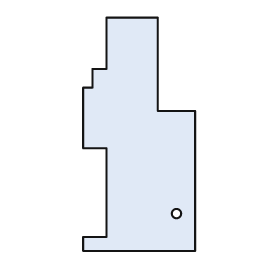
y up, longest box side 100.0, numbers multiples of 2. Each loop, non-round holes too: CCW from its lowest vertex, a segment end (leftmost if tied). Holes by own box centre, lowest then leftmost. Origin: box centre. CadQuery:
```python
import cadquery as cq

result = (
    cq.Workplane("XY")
    .moveTo(-24.0, -50.0)
    .lineTo(24.0, -50.0)
    .lineTo(24.0, 10.0)
    .lineTo(8.0, 10.0)
    .lineTo(8.0, 50.0)
    .lineTo(-14.0, 50.0)
    .lineTo(-14.0, 28.0)
    .lineTo(-20.0, 28.0)
    .lineTo(-20.0, 20.0)
    .lineTo(-24.0, 20.0)
    .lineTo(-24.0, -6.0)
    .lineTo(-14.0, -6.0)
    .lineTo(-14.0, -44.0)
    .lineTo(-24.0, -44.0)
    .close()
    .moveTo(16.0, -34.0)
    .circle(2.0)
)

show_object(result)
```